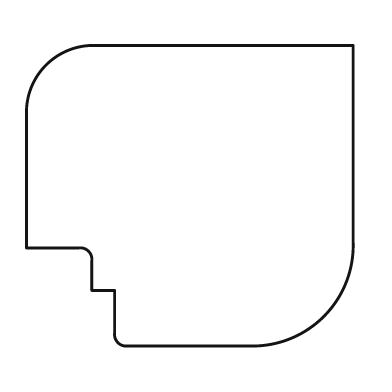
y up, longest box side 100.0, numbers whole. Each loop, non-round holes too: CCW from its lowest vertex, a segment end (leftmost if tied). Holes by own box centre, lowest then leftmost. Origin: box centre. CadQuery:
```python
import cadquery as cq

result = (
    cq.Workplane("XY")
    .moveTo(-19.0, -46.0)
    .lineTo(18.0, -46.0)
    .threePointArc((41.0, -37.0), (50.0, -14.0))
    .lineTo(50.0, 46.0)
    .lineTo(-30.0, 46.0)
    .threePointArc((-44.0, 40.0), (-50.0, 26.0))
    .lineTo(-50.0, -16.0)
    .lineTo(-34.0, -16.0)
    .threePointArc((-31.0, -17.0), (-30.0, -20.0))
    .lineTo(-30.0, -29.0)
    .lineTo(-23.0, -29.0)
    .lineTo(-23.0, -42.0)
    .threePointArc((-22.0, -45.0), (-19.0, -46.0))
    .close()
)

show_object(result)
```